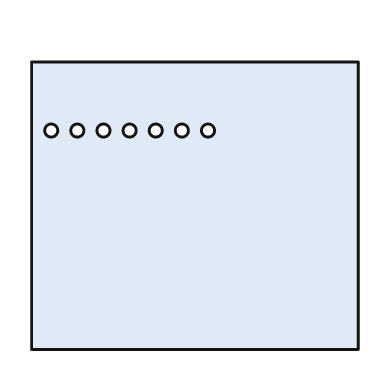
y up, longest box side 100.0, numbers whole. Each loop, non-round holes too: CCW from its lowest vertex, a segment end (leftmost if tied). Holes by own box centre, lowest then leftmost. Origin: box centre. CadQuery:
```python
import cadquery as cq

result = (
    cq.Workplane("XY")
    .moveTo(-50.0, -44.0)
    .lineTo(50.0, -44.0)
    .lineTo(50.0, 44.0)
    .lineTo(-50.0, 44.0)
    .close()
    .moveTo(-44.0, 23.0)
    .circle(2.0)
    .moveTo(-36.0, 23.0)
    .circle(2.0)
    .moveTo(-28.0, 23.0)
    .circle(2.0)
    .moveTo(-20.0, 23.0)
    .circle(2.0)
    .moveTo(-12.0, 23.0)
    .circle(2.0)
    .moveTo(-4.0, 23.0)
    .circle(2.0)
    .moveTo(4.0, 23.0)
    .circle(2.0)
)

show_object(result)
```